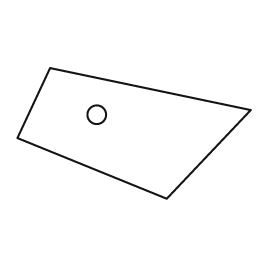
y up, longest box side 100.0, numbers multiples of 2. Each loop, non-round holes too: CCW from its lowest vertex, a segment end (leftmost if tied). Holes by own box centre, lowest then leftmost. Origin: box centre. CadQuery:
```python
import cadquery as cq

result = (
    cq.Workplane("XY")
    .moveTo(14.0, -28.0)
    .lineTo(50.0, 10.0)
    .lineTo(-36.0, 28.0)
    .lineTo(-50.0, -2.0)
    .close()
    .moveTo(-16.0, 8.0)
    .circle(4.0)
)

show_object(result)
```